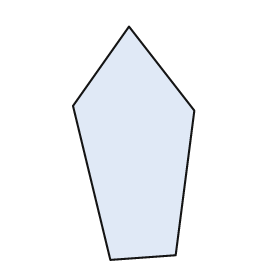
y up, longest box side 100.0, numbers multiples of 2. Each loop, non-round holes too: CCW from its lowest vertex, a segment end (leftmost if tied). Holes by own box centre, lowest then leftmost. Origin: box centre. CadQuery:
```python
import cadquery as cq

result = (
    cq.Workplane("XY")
    .moveTo(-10.0, -50.0)
    .lineTo(18.0, -48.0)
    .lineTo(26.0, 14.0)
    .lineTo(-2.0, 50.0)
    .lineTo(-26.0, 16.0)
    .close()
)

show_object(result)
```